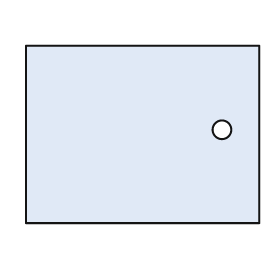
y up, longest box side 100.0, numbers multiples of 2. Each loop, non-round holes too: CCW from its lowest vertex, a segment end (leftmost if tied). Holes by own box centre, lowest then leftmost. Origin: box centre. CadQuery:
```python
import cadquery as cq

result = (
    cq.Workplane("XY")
    .moveTo(-50.0, -38.0)
    .lineTo(50.0, -38.0)
    .lineTo(50.0, 38.0)
    .lineTo(-50.0, 38.0)
    .close()
    .moveTo(34.0, 2.0)
    .circle(4.0)
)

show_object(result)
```